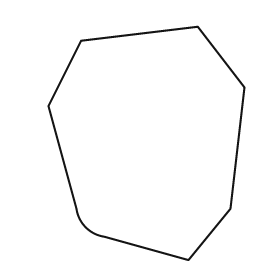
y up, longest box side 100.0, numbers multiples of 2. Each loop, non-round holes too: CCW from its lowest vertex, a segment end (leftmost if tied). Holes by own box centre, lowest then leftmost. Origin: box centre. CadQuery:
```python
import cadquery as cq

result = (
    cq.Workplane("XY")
    .moveTo(18.0, -50.0)
    .lineTo(36.0, -28.0)
    .lineTo(42.0, 24.0)
    .lineTo(22.0, 50.0)
    .lineTo(-28.0, 44.0)
    .lineTo(-42.0, 16.0)
    .lineTo(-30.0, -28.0)
    .threePointArc((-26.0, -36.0), (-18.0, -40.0))
    .close()
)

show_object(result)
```